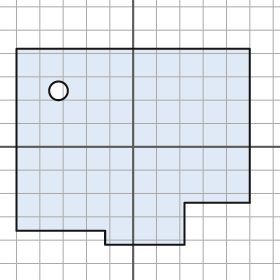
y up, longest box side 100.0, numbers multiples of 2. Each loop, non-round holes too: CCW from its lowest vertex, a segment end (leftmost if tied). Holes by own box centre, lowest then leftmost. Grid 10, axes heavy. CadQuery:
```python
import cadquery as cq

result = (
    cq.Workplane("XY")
    .moveTo(-12.0, -42.0)
    .lineTo(22.0, -42.0)
    .lineTo(22.0, -24.0)
    .lineTo(50.0, -24.0)
    .lineTo(50.0, 42.0)
    .lineTo(-50.0, 42.0)
    .lineTo(-50.0, -36.0)
    .lineTo(-12.0, -36.0)
    .close()
    .moveTo(-32.0, 24.0)
    .circle(4.0)
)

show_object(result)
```